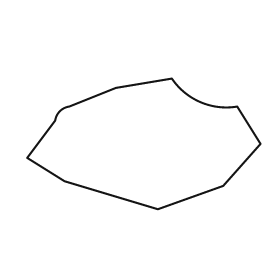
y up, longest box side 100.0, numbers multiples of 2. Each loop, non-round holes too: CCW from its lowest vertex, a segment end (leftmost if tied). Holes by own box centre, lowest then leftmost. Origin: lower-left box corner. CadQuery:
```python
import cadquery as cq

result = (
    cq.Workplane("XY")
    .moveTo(56.0, 0.0)
    .lineTo(84.0, 10.0)
    .lineTo(100.0, 28.0)
    .lineTo(90.0, 44.0)
    .threePointArc((74.0, 46.0), (62.0, 56.0))
    .lineTo(38.0, 52.0)
    .lineTo(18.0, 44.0)
    .threePointArc((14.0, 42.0), (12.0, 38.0))
    .lineTo(0.0, 22.0)
    .lineTo(16.0, 12.0)
    .close()
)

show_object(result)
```